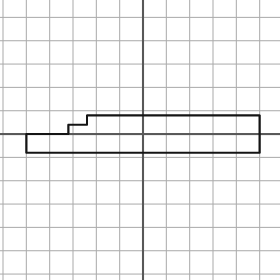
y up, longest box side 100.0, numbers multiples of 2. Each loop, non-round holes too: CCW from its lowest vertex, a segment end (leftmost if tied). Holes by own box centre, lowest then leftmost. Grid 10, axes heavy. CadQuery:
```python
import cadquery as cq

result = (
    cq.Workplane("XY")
    .moveTo(-50.0, -8.0)
    .lineTo(50.0, -8.0)
    .lineTo(50.0, 8.0)
    .lineTo(-24.0, 8.0)
    .lineTo(-24.0, 4.0)
    .lineTo(-32.0, 4.0)
    .lineTo(-32.0, 0.0)
    .lineTo(-50.0, 0.0)
    .close()
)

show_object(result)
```